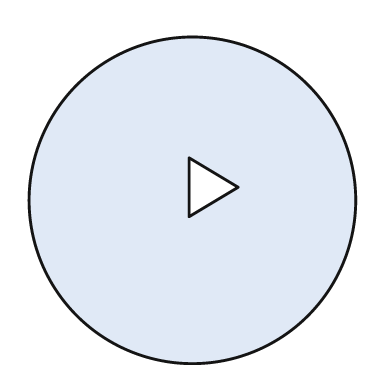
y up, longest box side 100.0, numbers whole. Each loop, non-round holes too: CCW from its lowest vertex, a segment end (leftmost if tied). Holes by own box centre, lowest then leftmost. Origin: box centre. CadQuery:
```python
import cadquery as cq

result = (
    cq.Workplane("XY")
    .moveTo(0.0, 0.0)
    .circle(50.0)
    .moveTo(-1.0, -5.0)
    .lineTo(14.0, 4.0)
    .lineTo(-1.0, 13.0)
    .close()
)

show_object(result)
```